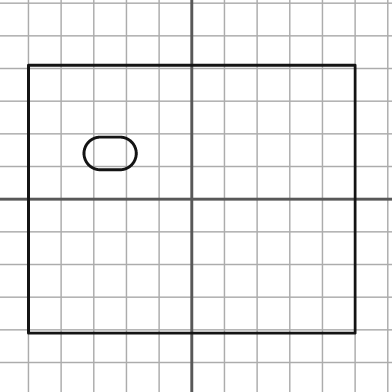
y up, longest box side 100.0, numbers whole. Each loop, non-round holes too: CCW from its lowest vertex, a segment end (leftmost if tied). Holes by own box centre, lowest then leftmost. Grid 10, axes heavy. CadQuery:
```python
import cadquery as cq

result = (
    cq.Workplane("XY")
    .moveTo(-50.0, -41.0)
    .lineTo(50.0, -41.0)
    .lineTo(50.0, 41.0)
    .lineTo(-50.0, 41.0)
    .close()
    .moveTo(-28.0, 9.0)
    .lineTo(-22.0, 9.0)
    .threePointArc((-17.0, 14.0), (-22.0, 19.0))
    .lineTo(-28.0, 19.0)
    .threePointArc((-33.0, 14.0), (-28.0, 9.0))
    .close()
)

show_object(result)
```